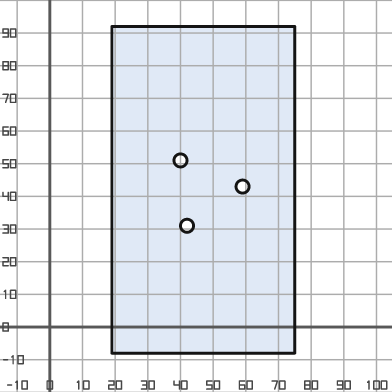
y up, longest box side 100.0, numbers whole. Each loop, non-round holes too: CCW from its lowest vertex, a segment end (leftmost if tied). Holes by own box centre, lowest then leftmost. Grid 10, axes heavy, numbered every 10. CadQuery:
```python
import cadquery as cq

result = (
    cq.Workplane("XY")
    .moveTo(19.0, -8.0)
    .lineTo(75.0, -8.0)
    .lineTo(75.0, 92.0)
    .lineTo(19.0, 92.0)
    .close()
    .moveTo(42.0, 31.0)
    .circle(2.0)
    .moveTo(59.0, 43.0)
    .circle(2.0)
    .moveTo(40.0, 51.0)
    .circle(2.0)
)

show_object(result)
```